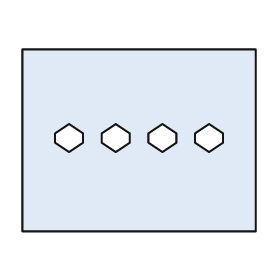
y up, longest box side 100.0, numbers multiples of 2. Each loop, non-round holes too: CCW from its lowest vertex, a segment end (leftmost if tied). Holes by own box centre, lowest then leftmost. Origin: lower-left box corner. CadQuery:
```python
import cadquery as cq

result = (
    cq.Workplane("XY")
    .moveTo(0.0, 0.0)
    .lineTo(100.0, 0.0)
    .lineTo(100.0, 78.0)
    .lineTo(0.0, 78.0)
    .close()
    .moveTo(20.0, 34.0)
    .lineTo(26.0, 38.0)
    .lineTo(26.0, 42.0)
    .lineTo(20.0, 46.0)
    .lineTo(14.0, 42.0)
    .lineTo(14.0, 38.0)
    .close()
    .moveTo(40.0, 34.0)
    .lineTo(46.0, 38.0)
    .lineTo(46.0, 42.0)
    .lineTo(40.0, 46.0)
    .lineTo(34.0, 42.0)
    .lineTo(34.0, 38.0)
    .close()
    .moveTo(60.0, 34.0)
    .lineTo(66.0, 38.0)
    .lineTo(66.0, 42.0)
    .lineTo(60.0, 46.0)
    .lineTo(54.0, 42.0)
    .lineTo(54.0, 38.0)
    .close()
    .moveTo(80.0, 34.0)
    .lineTo(86.0, 38.0)
    .lineTo(86.0, 42.0)
    .lineTo(80.0, 46.0)
    .lineTo(74.0, 42.0)
    .lineTo(74.0, 38.0)
    .close()
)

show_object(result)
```